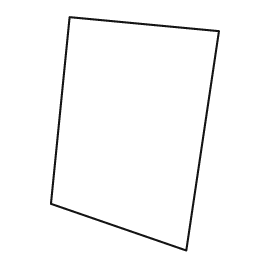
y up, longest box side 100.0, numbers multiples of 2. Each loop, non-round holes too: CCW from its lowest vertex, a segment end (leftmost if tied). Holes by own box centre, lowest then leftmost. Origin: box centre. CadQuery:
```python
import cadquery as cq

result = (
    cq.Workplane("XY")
    .moveTo(22.0, -50.0)
    .lineTo(36.0, 44.0)
    .lineTo(-28.0, 50.0)
    .lineTo(-36.0, -30.0)
    .close()
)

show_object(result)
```